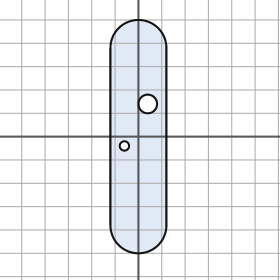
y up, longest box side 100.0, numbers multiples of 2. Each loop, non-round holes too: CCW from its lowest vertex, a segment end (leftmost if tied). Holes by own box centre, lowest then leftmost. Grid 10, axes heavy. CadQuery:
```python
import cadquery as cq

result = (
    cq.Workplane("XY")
    .moveTo(-12.0, -38.0)
    .threePointArc((0.0, -50.0), (12.0, -38.0))
    .lineTo(12.0, 38.0)
    .threePointArc((0.0, 50.0), (-12.0, 38.0))
    .close()
    .moveTo(-6.0, -4.0)
    .circle(2.0)
    .moveTo(4.0, 14.0)
    .circle(4.0)
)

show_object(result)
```